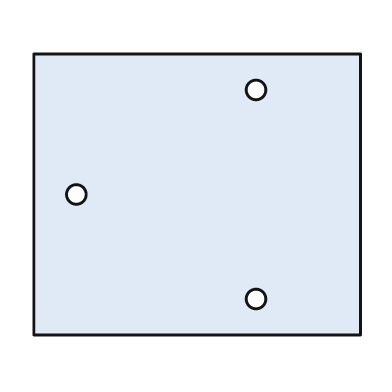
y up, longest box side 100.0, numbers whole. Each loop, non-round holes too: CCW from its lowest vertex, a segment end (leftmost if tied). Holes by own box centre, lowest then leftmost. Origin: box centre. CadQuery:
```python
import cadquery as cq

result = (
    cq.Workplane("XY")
    .moveTo(-50.0, -43.0)
    .lineTo(50.0, -43.0)
    .lineTo(50.0, 43.0)
    .lineTo(-50.0, 43.0)
    .close()
    .moveTo(18.0, -32.0)
    .circle(3.0)
    .moveTo(-37.0, 0.0)
    .circle(3.0)
    .moveTo(18.0, 32.0)
    .circle(3.0)
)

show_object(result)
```